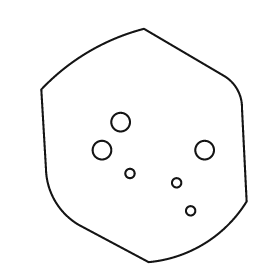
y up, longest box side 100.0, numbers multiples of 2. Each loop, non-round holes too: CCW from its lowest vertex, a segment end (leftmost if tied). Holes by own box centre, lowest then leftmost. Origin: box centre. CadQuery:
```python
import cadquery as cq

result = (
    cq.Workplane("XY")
    .moveTo(2.0, -50.0)
    .threePointArc((26.0, -42.0), (44.0, -24.0))
    .lineTo(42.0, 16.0)
    .threePointArc((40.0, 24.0), (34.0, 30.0))
    .lineTo(0.0, 50.0)
    .threePointArc((-24.0, 40.0), (-44.0, 24.0))
    .lineTo(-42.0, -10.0)
    .threePointArc((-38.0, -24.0), (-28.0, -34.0))
    .close()
    .moveTo(20.0, -28.0)
    .circle(2.0)
    .moveTo(14.0, -16.0)
    .circle(2.0)
    .moveTo(-6.0, -12.0)
    .circle(2.0)
    .moveTo(-18.0, -2.0)
    .circle(4.0)
    .moveTo(26.0, -2.0)
    .circle(4.0)
    .moveTo(-10.0, 10.0)
    .circle(4.0)
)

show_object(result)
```